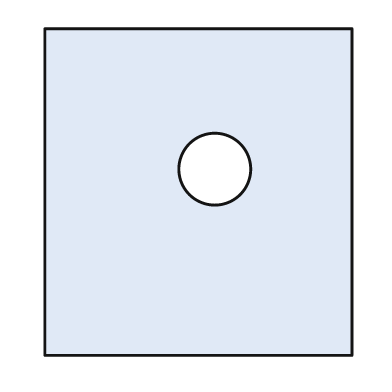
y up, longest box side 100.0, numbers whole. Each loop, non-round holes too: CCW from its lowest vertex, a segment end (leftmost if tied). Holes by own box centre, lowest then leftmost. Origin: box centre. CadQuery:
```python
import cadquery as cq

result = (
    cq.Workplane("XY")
    .moveTo(-47.0, -50.0)
    .lineTo(47.0, -50.0)
    .lineTo(47.0, 50.0)
    .lineTo(-47.0, 50.0)
    .close()
    .moveTo(5.0, 7.0)
    .circle(11.0)
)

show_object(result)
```